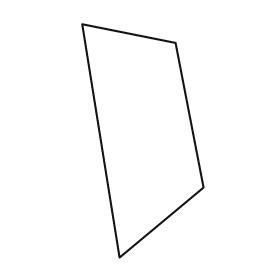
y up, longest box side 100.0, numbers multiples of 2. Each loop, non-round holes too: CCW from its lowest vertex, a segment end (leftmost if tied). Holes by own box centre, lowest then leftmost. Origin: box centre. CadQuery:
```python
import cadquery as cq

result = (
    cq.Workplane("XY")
    .moveTo(-10.0, -50.0)
    .lineTo(26.0, -20.0)
    .lineTo(14.0, 42.0)
    .lineTo(-26.0, 50.0)
    .close()
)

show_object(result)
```